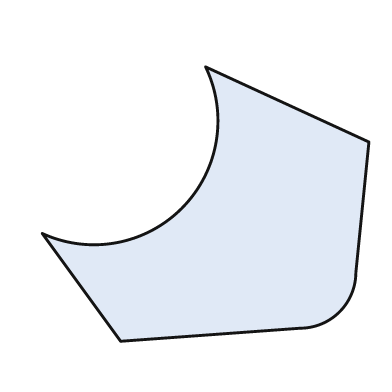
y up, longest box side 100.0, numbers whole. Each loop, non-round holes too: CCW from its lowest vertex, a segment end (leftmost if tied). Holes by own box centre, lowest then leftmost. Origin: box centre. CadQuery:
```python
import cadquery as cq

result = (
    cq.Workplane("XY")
    .moveTo(-26.0, -42.0)
    .lineTo(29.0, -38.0)
    .threePointArc((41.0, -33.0), (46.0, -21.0))
    .lineTo(50.0, 19.0)
    .lineTo(0.0, 42.0)
    .threePointArc((-7.0, -1.0), (-50.0, -9.0))
    .close()
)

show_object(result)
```